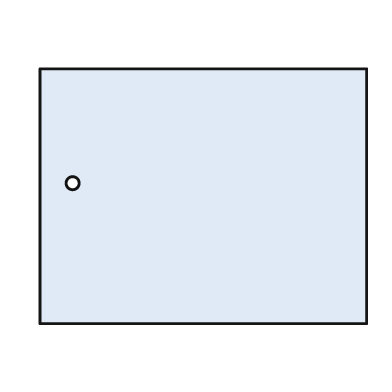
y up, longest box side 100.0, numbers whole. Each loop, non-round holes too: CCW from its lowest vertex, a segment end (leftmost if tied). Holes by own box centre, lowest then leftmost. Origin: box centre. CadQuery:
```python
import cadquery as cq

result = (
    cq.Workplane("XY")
    .moveTo(-50.0, -39.0)
    .lineTo(50.0, -39.0)
    .lineTo(50.0, 39.0)
    .lineTo(-50.0, 39.0)
    .close()
    .moveTo(-40.0, 4.0)
    .circle(2.0)
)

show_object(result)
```